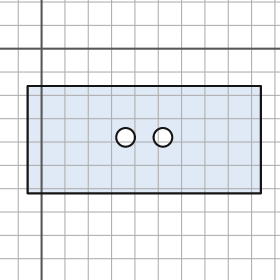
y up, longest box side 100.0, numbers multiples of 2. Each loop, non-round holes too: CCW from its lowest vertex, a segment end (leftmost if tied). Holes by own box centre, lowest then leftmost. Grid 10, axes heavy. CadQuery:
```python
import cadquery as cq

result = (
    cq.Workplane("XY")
    .moveTo(-6.0, -62.0)
    .lineTo(94.0, -62.0)
    .lineTo(94.0, -16.0)
    .lineTo(-6.0, -16.0)
    .close()
    .moveTo(36.0, -38.0)
    .circle(4.0)
    .moveTo(52.0, -38.0)
    .circle(4.0)
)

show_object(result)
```